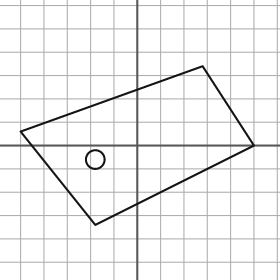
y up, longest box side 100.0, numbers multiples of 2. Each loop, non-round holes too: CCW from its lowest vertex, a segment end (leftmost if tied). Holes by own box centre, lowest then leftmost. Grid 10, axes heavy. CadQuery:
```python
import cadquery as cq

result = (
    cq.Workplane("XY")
    .moveTo(-18.0, -34.0)
    .lineTo(50.0, 0.0)
    .lineTo(28.0, 34.0)
    .lineTo(-50.0, 6.0)
    .close()
    .moveTo(-18.0, -6.0)
    .circle(4.0)
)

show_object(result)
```